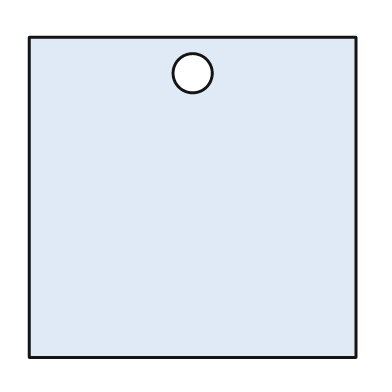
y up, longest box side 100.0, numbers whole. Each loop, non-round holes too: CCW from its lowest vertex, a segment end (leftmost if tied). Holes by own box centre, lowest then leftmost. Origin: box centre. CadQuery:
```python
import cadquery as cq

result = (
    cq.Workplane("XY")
    .moveTo(-50.0, -49.0)
    .lineTo(50.0, -49.0)
    .lineTo(50.0, 49.0)
    .lineTo(-50.0, 49.0)
    .close()
    .moveTo(0.0, 38.0)
    .circle(6.0)
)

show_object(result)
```